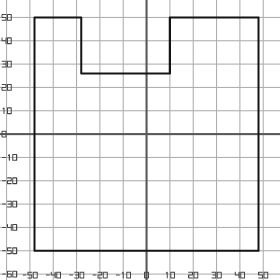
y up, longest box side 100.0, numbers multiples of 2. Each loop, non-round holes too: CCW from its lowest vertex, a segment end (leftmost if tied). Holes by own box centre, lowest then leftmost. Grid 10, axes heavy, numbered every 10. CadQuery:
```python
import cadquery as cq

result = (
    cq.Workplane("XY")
    .moveTo(-48.0, -50.0)
    .lineTo(48.0, -50.0)
    .lineTo(48.0, 50.0)
    .lineTo(10.0, 50.0)
    .lineTo(10.0, 26.0)
    .lineTo(-28.0, 26.0)
    .lineTo(-28.0, 50.0)
    .lineTo(-48.0, 50.0)
    .close()
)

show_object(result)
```